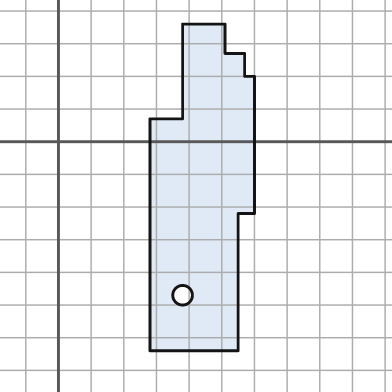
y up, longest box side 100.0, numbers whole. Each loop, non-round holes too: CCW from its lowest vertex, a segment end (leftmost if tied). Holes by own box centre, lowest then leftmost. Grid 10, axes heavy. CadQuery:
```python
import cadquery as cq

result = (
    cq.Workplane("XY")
    .moveTo(28.0, -64.0)
    .lineTo(55.0, -64.0)
    .lineTo(55.0, -22.0)
    .lineTo(60.0, -22.0)
    .lineTo(60.0, 20.0)
    .lineTo(57.0, 20.0)
    .lineTo(57.0, 27.0)
    .lineTo(51.0, 27.0)
    .lineTo(51.0, 36.0)
    .lineTo(38.0, 36.0)
    .lineTo(38.0, 7.0)
    .lineTo(28.0, 7.0)
    .close()
    .moveTo(38.0, -47.0)
    .circle(3.0)
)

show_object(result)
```